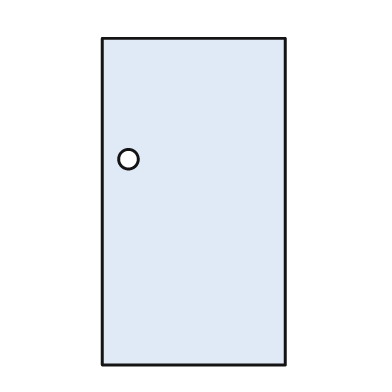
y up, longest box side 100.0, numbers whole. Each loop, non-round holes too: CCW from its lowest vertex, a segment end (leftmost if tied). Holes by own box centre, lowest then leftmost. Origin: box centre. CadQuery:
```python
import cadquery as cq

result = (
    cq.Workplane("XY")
    .moveTo(-28.0, -50.0)
    .lineTo(28.0, -50.0)
    .lineTo(28.0, 50.0)
    .lineTo(-28.0, 50.0)
    .close()
    .moveTo(-20.0, 13.0)
    .circle(3.0)
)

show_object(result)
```